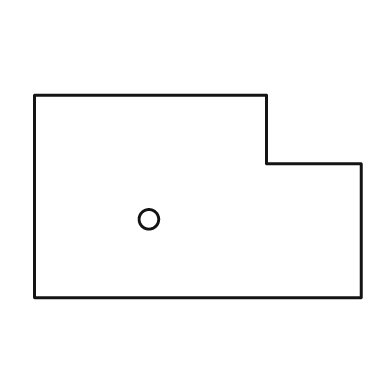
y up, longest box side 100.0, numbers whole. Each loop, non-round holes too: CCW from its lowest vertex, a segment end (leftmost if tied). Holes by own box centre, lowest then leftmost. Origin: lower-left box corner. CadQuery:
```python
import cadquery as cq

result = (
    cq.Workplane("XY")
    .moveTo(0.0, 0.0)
    .lineTo(100.0, 0.0)
    .lineTo(100.0, 41.0)
    .lineTo(71.0, 41.0)
    .lineTo(71.0, 62.0)
    .lineTo(0.0, 62.0)
    .close()
    .moveTo(35.0, 24.0)
    .circle(3.0)
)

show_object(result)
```